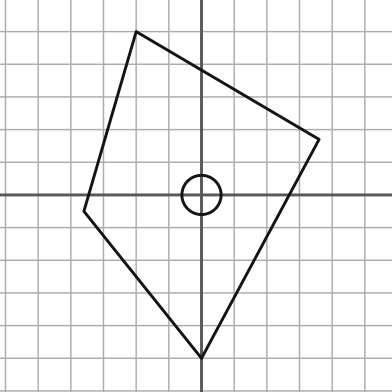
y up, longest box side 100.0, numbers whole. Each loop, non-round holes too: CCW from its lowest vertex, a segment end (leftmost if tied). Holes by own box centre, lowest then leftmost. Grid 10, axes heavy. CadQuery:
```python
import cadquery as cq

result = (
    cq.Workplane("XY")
    .moveTo(0.0, -50.0)
    .lineTo(36.0, 17.0)
    .lineTo(-20.0, 50.0)
    .lineTo(-36.0, -5.0)
    .close()
    .moveTo(0.0, 0.0)
    .circle(6.0)
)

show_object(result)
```